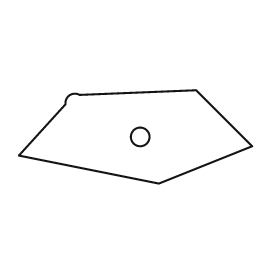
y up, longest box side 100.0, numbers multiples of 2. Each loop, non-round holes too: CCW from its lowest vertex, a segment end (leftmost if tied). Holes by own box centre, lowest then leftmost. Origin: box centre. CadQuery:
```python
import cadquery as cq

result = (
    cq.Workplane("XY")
    .moveTo(10.0, -20.0)
    .lineTo(50.0, -4.0)
    .lineTo(26.0, 20.0)
    .lineTo(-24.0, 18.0)
    .threePointArc((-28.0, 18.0), (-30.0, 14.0))
    .lineTo(-50.0, -8.0)
    .close()
    .moveTo(2.0, 0.0)
    .circle(4.0)
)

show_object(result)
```